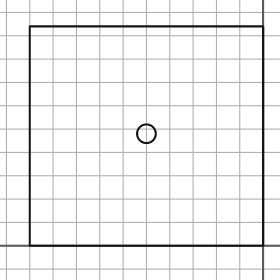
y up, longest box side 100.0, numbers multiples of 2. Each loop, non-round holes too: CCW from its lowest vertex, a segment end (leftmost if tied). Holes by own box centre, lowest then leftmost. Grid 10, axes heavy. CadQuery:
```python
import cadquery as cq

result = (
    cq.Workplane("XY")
    .moveTo(-100.0, 0.0)
    .lineTo(0.0, 0.0)
    .lineTo(0.0, 94.0)
    .lineTo(-100.0, 94.0)
    .close()
    .moveTo(-50.0, 48.0)
    .circle(4.0)
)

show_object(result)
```